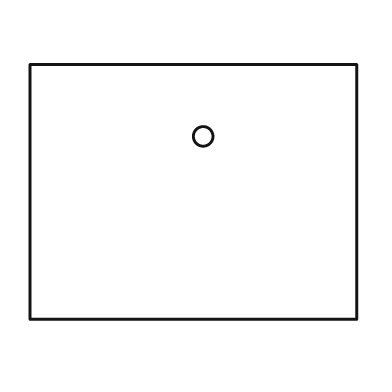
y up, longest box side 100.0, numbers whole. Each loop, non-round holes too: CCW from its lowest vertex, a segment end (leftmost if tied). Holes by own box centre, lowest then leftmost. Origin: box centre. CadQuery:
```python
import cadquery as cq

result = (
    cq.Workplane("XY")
    .moveTo(-50.0, -39.0)
    .lineTo(50.0, -39.0)
    .lineTo(50.0, 39.0)
    .lineTo(-50.0, 39.0)
    .close()
    .moveTo(3.0, 17.0)
    .circle(3.0)
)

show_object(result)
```